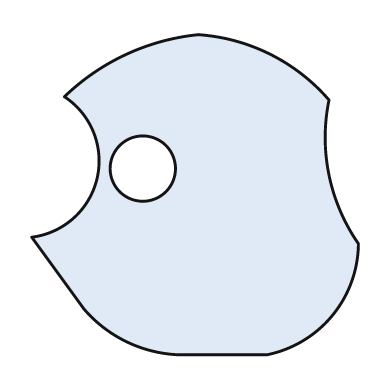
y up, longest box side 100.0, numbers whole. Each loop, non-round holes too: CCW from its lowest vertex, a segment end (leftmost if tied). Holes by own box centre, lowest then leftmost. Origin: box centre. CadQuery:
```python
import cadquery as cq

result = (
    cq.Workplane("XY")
    .moveTo(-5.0, -49.0)
    .lineTo(22.0, -49.0)
    .threePointArc((42.0, -37.0), (50.0, -15.0))
    .threePointArc((41.0, 6.0), (41.0, 29.0))
    .threePointArc((23.0, 43.0), (1.0, 49.0))
    .threePointArc((-21.0, 43.0), (-40.0, 30.0))
    .threePointArc((-30.0, 5.0), (-50.0, -13.0))
    .lineTo(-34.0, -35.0)
    .threePointArc((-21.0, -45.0), (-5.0, -49.0))
    .close()
    .moveTo(-16.0, 8.0)
    .circle(10.0)
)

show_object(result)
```